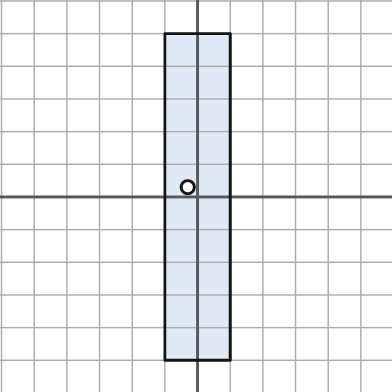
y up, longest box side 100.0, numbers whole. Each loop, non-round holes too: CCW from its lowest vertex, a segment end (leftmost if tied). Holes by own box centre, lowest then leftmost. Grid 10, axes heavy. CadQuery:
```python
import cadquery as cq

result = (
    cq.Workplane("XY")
    .moveTo(-10.0, -50.0)
    .lineTo(10.0, -50.0)
    .lineTo(10.0, 50.0)
    .lineTo(-10.0, 50.0)
    .close()
    .moveTo(-3.0, 3.0)
    .circle(2.0)
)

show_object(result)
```